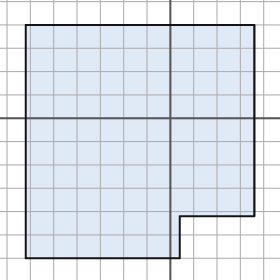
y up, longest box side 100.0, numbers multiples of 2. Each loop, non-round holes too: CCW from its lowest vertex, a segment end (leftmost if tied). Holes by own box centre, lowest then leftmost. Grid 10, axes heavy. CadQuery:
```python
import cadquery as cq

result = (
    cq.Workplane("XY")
    .moveTo(-62.0, -60.0)
    .lineTo(4.0, -60.0)
    .lineTo(4.0, -42.0)
    .lineTo(36.0, -42.0)
    .lineTo(36.0, 40.0)
    .lineTo(-62.0, 40.0)
    .close()
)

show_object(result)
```